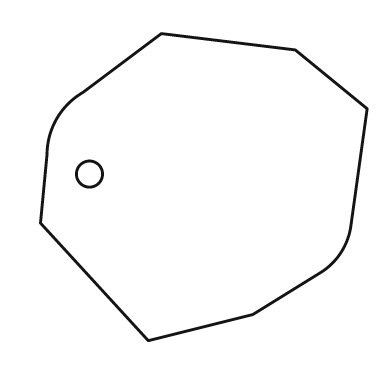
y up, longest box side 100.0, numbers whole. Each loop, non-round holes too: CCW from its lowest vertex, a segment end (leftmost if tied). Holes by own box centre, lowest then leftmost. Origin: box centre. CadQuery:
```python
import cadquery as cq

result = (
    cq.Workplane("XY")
    .moveTo(-17.0, -47.0)
    .lineTo(15.0, -39.0)
    .lineTo(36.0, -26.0)
    .threePointArc((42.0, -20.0), (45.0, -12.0))
    .lineTo(50.0, 24.0)
    .lineTo(28.0, 42.0)
    .lineTo(-13.0, 47.0)
    .lineTo(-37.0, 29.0)
    .threePointArc((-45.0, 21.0), (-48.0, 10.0))
    .lineTo(-50.0, -11.0)
    .close()
    .moveTo(-35.0, 4.0)
    .circle(4.0)
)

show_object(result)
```